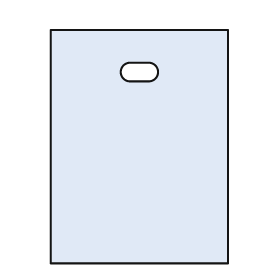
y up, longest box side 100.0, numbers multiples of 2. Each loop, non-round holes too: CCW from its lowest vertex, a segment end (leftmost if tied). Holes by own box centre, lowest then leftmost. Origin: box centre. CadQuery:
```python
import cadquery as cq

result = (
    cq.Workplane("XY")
    .moveTo(-38.0, -50.0)
    .lineTo(38.0, -50.0)
    .lineTo(38.0, 50.0)
    .lineTo(-38.0, 50.0)
    .close()
    .moveTo(-4.0, 28.0)
    .lineTo(4.0, 28.0)
    .threePointArc((8.0, 32.0), (4.0, 36.0))
    .lineTo(-4.0, 36.0)
    .threePointArc((-8.0, 32.0), (-4.0, 28.0))
    .close()
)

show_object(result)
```